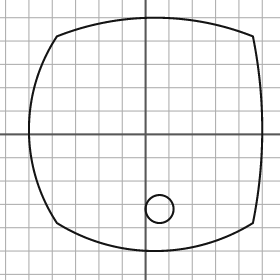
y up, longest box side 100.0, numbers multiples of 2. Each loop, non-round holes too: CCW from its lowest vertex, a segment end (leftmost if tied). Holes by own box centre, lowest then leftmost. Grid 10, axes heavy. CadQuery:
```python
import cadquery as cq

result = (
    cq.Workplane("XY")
    .moveTo(-38.0, -38.0)
    .threePointArc((4.0, -50.0), (46.0, -38.0))
    .threePointArc((50.0, 2.0), (46.0, 42.0))
    .threePointArc((4.0, 50.0), (-38.0, 42.0))
    .threePointArc((-50.0, 2.0), (-38.0, -38.0))
    .close()
    .moveTo(6.0, -32.0)
    .circle(6.0)
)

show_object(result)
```